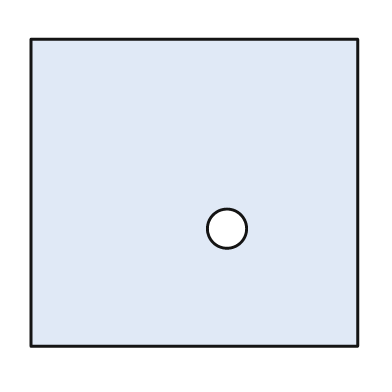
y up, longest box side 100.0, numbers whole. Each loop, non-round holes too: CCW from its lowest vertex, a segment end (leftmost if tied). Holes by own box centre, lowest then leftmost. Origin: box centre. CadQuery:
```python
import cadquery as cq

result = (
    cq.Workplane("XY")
    .moveTo(-50.0, -47.0)
    .lineTo(50.0, -47.0)
    .lineTo(50.0, 47.0)
    .lineTo(-50.0, 47.0)
    .close()
    .moveTo(10.0, -11.0)
    .circle(6.0)
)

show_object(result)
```